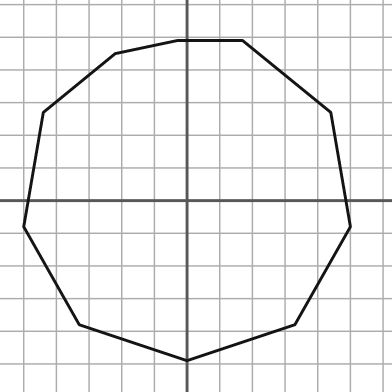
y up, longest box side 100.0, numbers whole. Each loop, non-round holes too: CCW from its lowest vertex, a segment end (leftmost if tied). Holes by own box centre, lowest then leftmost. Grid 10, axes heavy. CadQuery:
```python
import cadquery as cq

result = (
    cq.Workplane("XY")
    .moveTo(0.0, -49.0)
    .lineTo(33.0, -38.0)
    .lineTo(50.0, -8.0)
    .lineTo(44.0, 27.0)
    .lineTo(17.0, 49.0)
    .lineTo(-3.0, 49.0)
    .lineTo(-22.0, 45.0)
    .lineTo(-44.0, 27.0)
    .lineTo(-50.0, -8.0)
    .lineTo(-33.0, -38.0)
    .close()
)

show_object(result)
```